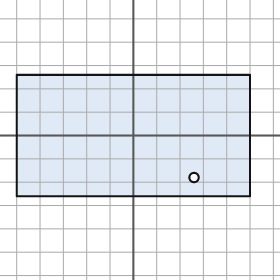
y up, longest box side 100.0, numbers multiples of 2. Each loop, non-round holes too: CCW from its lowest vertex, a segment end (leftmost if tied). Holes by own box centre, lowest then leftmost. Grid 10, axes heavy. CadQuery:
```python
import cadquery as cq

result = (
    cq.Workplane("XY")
    .moveTo(-50.0, -26.0)
    .lineTo(50.0, -26.0)
    .lineTo(50.0, 26.0)
    .lineTo(-50.0, 26.0)
    .close()
    .moveTo(26.0, -18.0)
    .circle(2.0)
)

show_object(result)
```